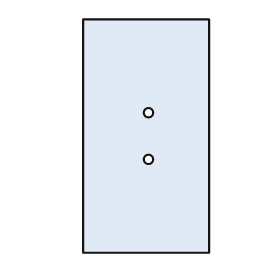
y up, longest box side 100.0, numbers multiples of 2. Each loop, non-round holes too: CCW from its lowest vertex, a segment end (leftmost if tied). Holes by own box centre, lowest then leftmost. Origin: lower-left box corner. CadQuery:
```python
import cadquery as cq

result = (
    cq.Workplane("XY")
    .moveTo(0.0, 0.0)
    .lineTo(54.0, 0.0)
    .lineTo(54.0, 100.0)
    .lineTo(0.0, 100.0)
    .close()
    .moveTo(28.0, 40.0)
    .circle(2.0)
    .moveTo(28.0, 60.0)
    .circle(2.0)
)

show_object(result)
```